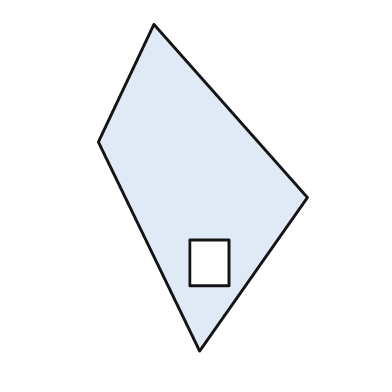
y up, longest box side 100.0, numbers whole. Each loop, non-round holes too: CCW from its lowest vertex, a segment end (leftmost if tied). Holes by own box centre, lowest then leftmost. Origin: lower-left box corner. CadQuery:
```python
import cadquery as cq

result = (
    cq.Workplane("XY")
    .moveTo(31.0, 0.0)
    .lineTo(64.0, 47.0)
    .lineTo(17.0, 100.0)
    .lineTo(0.0, 64.0)
    .close()
    .moveTo(28.0, 20.0)
    .lineTo(40.0, 20.0)
    .lineTo(40.0, 34.0)
    .lineTo(28.0, 34.0)
    .close()
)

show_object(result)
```